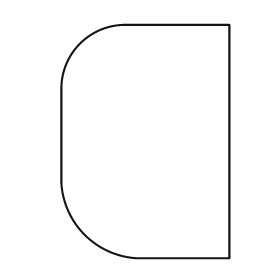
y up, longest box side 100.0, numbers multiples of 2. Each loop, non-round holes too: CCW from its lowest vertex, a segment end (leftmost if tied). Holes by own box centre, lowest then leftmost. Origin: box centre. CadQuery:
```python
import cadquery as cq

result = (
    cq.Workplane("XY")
    .moveTo(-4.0, -50.0)
    .lineTo(36.0, -50.0)
    .lineTo(36.0, 50.0)
    .lineTo(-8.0, 50.0)
    .threePointArc((-28.0, 42.0), (-36.0, 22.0))
    .lineTo(-36.0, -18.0)
    .threePointArc((-26.0, -40.0), (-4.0, -50.0))
    .close()
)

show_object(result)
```